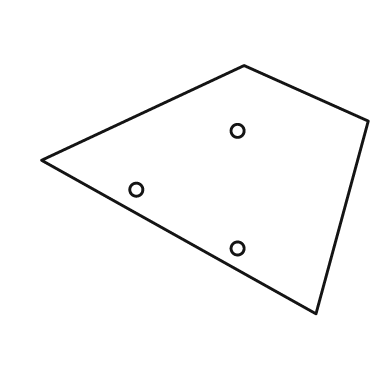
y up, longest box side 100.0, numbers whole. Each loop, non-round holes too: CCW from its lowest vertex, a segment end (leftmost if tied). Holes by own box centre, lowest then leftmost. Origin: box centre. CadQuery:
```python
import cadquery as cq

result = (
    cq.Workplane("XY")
    .moveTo(34.0, -38.0)
    .lineTo(50.0, 21.0)
    .lineTo(12.0, 38.0)
    .lineTo(-50.0, 9.0)
    .close()
    .moveTo(10.0, -18.0)
    .circle(2.0)
    .moveTo(-21.0, 0.0)
    .circle(2.0)
    .moveTo(10.0, 18.0)
    .circle(2.0)
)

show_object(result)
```